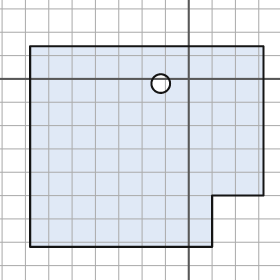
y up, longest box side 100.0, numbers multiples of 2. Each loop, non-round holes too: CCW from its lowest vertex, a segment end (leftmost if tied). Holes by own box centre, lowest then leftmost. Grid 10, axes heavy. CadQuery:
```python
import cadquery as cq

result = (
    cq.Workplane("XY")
    .moveTo(-68.0, -72.0)
    .lineTo(10.0, -72.0)
    .lineTo(10.0, -50.0)
    .lineTo(32.0, -50.0)
    .lineTo(32.0, 14.0)
    .lineTo(-68.0, 14.0)
    .close()
    .moveTo(-12.0, -2.0)
    .circle(4.0)
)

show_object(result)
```